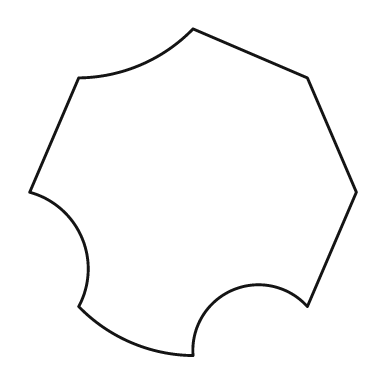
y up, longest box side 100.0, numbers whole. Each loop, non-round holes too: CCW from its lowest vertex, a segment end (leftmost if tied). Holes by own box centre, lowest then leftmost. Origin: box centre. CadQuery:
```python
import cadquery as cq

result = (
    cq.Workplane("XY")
    .moveTo(0.0, -50.0)
    .threePointArc((12.0, -30.0), (35.0, -35.0))
    .lineTo(50.0, 0.0)
    .lineTo(35.0, 35.0)
    .lineTo(0.0, 50.0)
    .threePointArc((-16.0, 39.0), (-35.0, 35.0))
    .lineTo(-50.0, 0.0)
    .threePointArc((-34.0, -14.0), (-35.0, -35.0))
    .threePointArc((-19.0, -46.0), (0.0, -50.0))
    .close()
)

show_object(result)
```